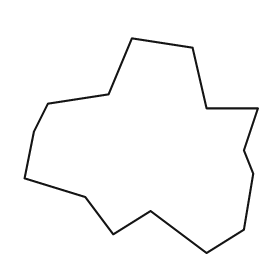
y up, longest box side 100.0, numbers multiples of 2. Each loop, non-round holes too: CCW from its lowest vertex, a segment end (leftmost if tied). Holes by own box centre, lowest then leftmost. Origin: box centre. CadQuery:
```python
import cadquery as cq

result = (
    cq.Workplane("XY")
    .moveTo(28.0, -46.0)
    .lineTo(44.0, -36.0)
    .lineTo(48.0, -12.0)
    .lineTo(44.0, -2.0)
    .lineTo(50.0, 16.0)
    .lineTo(28.0, 16.0)
    .lineTo(22.0, 42.0)
    .lineTo(-4.0, 46.0)
    .lineTo(-14.0, 22.0)
    .lineTo(-40.0, 18.0)
    .lineTo(-46.0, 6.0)
    .lineTo(-50.0, -14.0)
    .lineTo(-24.0, -22.0)
    .lineTo(-12.0, -38.0)
    .lineTo(4.0, -28.0)
    .close()
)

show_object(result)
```